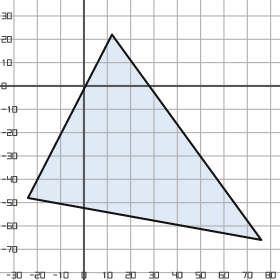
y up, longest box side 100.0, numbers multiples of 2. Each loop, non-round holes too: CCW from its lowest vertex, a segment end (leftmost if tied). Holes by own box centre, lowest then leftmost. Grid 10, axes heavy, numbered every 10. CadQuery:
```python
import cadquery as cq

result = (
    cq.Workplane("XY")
    .moveTo(76.0, -66.0)
    .lineTo(12.0, 22.0)
    .lineTo(-24.0, -48.0)
    .close()
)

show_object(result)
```